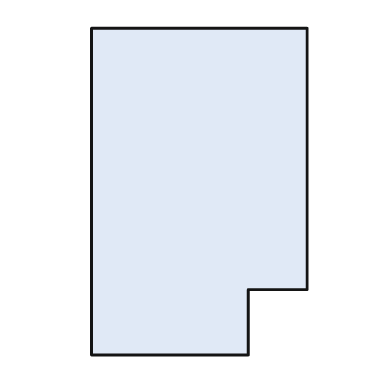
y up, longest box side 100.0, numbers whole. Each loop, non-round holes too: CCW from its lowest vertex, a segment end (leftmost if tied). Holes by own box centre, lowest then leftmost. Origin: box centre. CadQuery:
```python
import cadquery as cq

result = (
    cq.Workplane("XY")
    .moveTo(-33.0, -50.0)
    .lineTo(15.0, -50.0)
    .lineTo(15.0, -30.0)
    .lineTo(33.0, -30.0)
    .lineTo(33.0, 50.0)
    .lineTo(-33.0, 50.0)
    .close()
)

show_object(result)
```